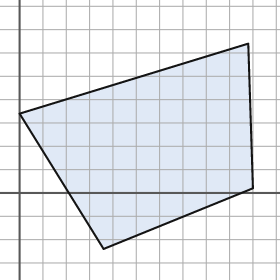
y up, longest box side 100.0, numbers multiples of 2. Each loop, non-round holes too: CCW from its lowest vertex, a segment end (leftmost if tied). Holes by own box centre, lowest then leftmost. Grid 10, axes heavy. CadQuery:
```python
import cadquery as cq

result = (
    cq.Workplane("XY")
    .moveTo(36.0, -24.0)
    .lineTo(100.0, 2.0)
    .lineTo(98.0, 64.0)
    .lineTo(0.0, 34.0)
    .close()
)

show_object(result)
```